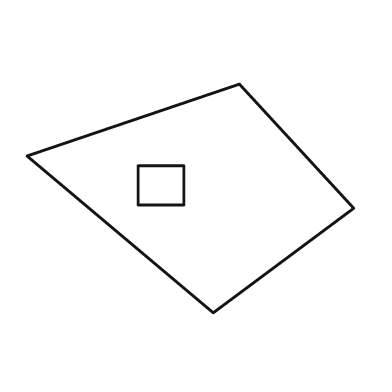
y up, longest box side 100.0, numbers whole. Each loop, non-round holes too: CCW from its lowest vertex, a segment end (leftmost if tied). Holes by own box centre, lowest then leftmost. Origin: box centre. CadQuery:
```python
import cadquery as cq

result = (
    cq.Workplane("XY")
    .moveTo(7.0, -35.0)
    .lineTo(50.0, -3.0)
    .lineTo(15.0, 35.0)
    .lineTo(-50.0, 13.0)
    .close()
    .moveTo(-16.0, -2.0)
    .lineTo(-2.0, -2.0)
    .lineTo(-2.0, 10.0)
    .lineTo(-16.0, 10.0)
    .close()
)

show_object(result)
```